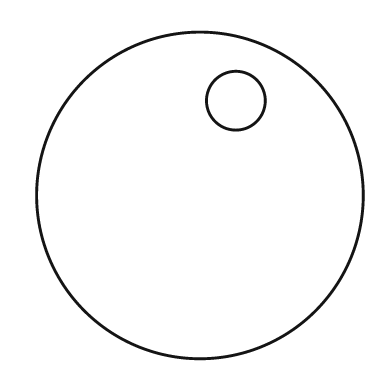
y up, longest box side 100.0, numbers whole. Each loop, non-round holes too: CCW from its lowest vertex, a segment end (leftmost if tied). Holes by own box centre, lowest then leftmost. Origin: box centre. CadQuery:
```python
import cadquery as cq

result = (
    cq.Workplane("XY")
    .moveTo(0.0, 0.0)
    .circle(50.0)
    .moveTo(11.0, 29.0)
    .circle(9.0)
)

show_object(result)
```